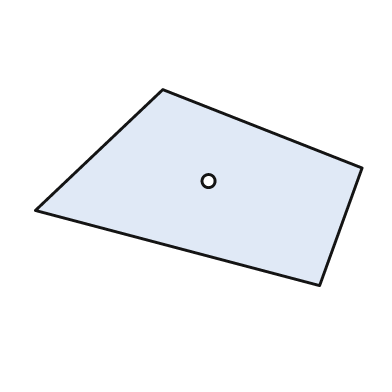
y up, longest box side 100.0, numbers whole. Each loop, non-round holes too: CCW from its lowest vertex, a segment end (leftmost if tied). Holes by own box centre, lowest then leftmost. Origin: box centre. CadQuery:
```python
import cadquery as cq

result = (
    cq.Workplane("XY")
    .moveTo(37.0, -30.0)
    .lineTo(50.0, 6.0)
    .lineTo(-11.0, 30.0)
    .lineTo(-50.0, -7.0)
    .close()
    .moveTo(3.0, 2.0)
    .circle(2.0)
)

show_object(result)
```